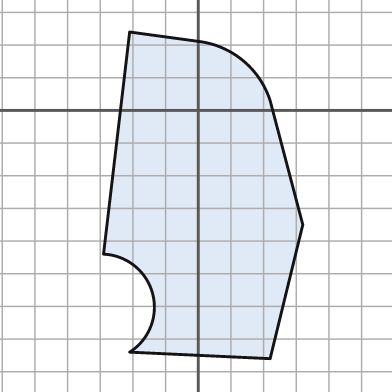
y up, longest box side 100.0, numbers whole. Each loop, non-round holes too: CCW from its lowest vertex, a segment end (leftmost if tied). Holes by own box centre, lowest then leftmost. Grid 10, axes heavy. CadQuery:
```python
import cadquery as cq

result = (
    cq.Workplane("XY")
    .moveTo(22.0, -76.0)
    .lineTo(32.0, -35.0)
    .lineTo(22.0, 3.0)
    .threePointArc((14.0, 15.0), (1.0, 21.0))
    .lineTo(-21.0, 24.0)
    .lineTo(-29.0, -44.0)
    .threePointArc((-14.0, -56.0), (-21.0, -74.0))
    .close()
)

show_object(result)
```